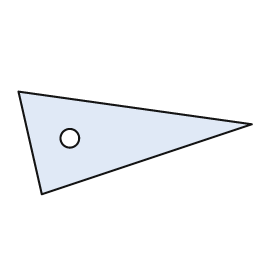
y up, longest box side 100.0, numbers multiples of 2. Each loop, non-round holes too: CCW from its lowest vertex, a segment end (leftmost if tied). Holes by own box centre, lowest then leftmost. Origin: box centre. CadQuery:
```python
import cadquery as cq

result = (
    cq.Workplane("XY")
    .moveTo(-40.0, -22.0)
    .lineTo(50.0, 8.0)
    .lineTo(-50.0, 22.0)
    .close()
    .moveTo(-28.0, 2.0)
    .circle(4.0)
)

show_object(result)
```